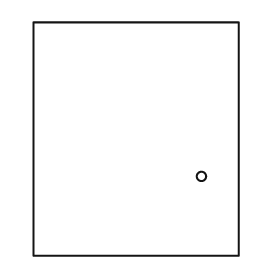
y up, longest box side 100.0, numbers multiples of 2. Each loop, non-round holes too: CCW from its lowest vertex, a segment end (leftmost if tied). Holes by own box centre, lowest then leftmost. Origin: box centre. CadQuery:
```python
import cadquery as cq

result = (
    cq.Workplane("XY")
    .moveTo(-44.0, -50.0)
    .lineTo(44.0, -50.0)
    .lineTo(44.0, 50.0)
    .lineTo(-44.0, 50.0)
    .close()
    .moveTo(28.0, -16.0)
    .circle(2.0)
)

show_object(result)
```